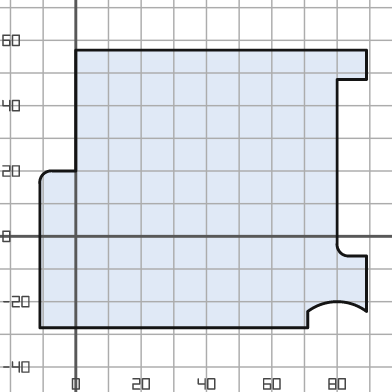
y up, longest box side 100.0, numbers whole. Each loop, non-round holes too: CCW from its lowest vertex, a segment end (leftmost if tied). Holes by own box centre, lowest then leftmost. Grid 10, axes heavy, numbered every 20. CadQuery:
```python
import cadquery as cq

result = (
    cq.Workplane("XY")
    .moveTo(-11.0, -28.0)
    .lineTo(71.0, -28.0)
    .lineTo(71.0, -23.0)
    .threePointArc((80.0, -20.0), (89.0, -23.0))
    .lineTo(89.0, -6.0)
    .lineTo(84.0, -6.0)
    .threePointArc((81.0, -5.0), (80.0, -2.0))
    .lineTo(80.0, 48.0)
    .lineTo(89.0, 48.0)
    .lineTo(89.0, 57.0)
    .lineTo(0.0, 57.0)
    .lineTo(0.0, 20.0)
    .lineTo(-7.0, 20.0)
    .threePointArc((-10.0, 19.0), (-11.0, 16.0))
    .close()
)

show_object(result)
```